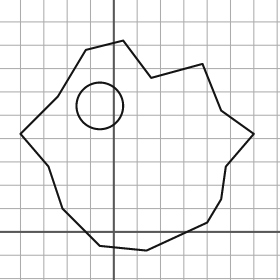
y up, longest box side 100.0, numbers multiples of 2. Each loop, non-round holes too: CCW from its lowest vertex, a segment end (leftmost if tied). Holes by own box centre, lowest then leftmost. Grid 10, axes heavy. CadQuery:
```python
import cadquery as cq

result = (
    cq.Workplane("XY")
    .moveTo(14.0, -8.0)
    .lineTo(40.0, 4.0)
    .lineTo(46.0, 14.0)
    .lineTo(48.0, 28.0)
    .lineTo(60.0, 42.0)
    .lineTo(46.0, 52.0)
    .lineTo(38.0, 72.0)
    .lineTo(16.0, 66.0)
    .lineTo(4.0, 82.0)
    .lineTo(-12.0, 78.0)
    .lineTo(-24.0, 58.0)
    .lineTo(-40.0, 42.0)
    .lineTo(-28.0, 28.0)
    .lineTo(-22.0, 10.0)
    .lineTo(-6.0, -6.0)
    .close()
    .moveTo(-6.0, 54.0)
    .circle(10.0)
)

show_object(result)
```